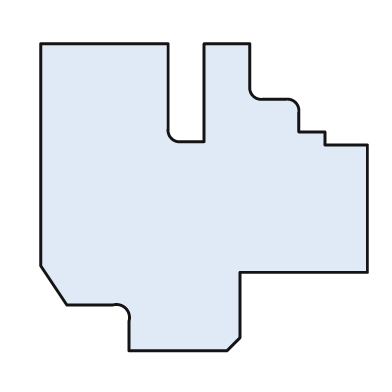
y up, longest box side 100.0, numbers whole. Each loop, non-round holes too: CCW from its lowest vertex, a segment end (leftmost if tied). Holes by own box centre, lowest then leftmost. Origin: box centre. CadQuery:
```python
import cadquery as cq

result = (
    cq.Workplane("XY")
    .moveTo(-23.0, -47.0)
    .lineTo(7.0, -47.0)
    .lineTo(11.0, -43.0)
    .lineTo(11.0, -23.0)
    .lineTo(50.0, -23.0)
    .lineTo(50.0, 16.0)
    .lineTo(37.0, 16.0)
    .lineTo(37.0, 20.0)
    .lineTo(29.0, 20.0)
    .lineTo(29.0, 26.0)
    .threePointArc((28.0, 29.0), (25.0, 30.0))
    .lineTo(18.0, 30.0)
    .threePointArc((15.0, 31.0), (14.0, 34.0))
    .lineTo(14.0, 47.0)
    .lineTo(0.0, 47.0)
    .lineTo(0.0, 17.0)
    .lineTo(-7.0, 17.0)
    .threePointArc((-10.0, 18.0), (-11.0, 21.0))
    .lineTo(-11.0, 47.0)
    .lineTo(-50.0, 47.0)
    .lineTo(-50.0, -21.0)
    .lineTo(-42.0, -33.0)
    .lineTo(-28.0, -33.0)
    .threePointArc((-24.0, -34.0), (-23.0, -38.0))
    .close()
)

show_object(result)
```